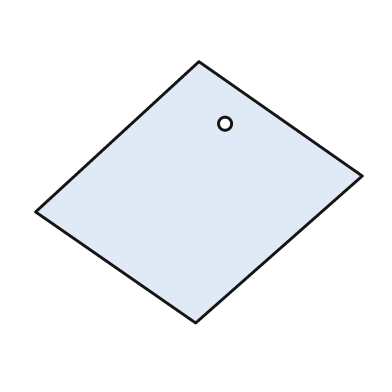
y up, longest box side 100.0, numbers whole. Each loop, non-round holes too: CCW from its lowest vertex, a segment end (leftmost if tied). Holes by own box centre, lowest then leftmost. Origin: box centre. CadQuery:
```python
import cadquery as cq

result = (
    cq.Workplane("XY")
    .moveTo(-1.0, -40.0)
    .lineTo(50.0, 5.0)
    .lineTo(0.0, 40.0)
    .lineTo(-50.0, -6.0)
    .close()
    .moveTo(8.0, 21.0)
    .circle(2.0)
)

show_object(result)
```